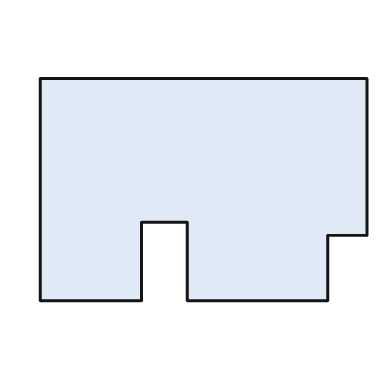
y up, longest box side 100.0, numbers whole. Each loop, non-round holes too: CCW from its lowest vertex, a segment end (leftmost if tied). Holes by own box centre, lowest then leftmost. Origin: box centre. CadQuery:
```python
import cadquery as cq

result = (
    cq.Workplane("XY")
    .moveTo(-50.0, -34.0)
    .lineTo(-19.0, -34.0)
    .lineTo(-19.0, -10.0)
    .lineTo(-5.0, -10.0)
    .lineTo(-5.0, -34.0)
    .lineTo(38.0, -34.0)
    .lineTo(38.0, -14.0)
    .lineTo(50.0, -14.0)
    .lineTo(50.0, 34.0)
    .lineTo(-50.0, 34.0)
    .close()
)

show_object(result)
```